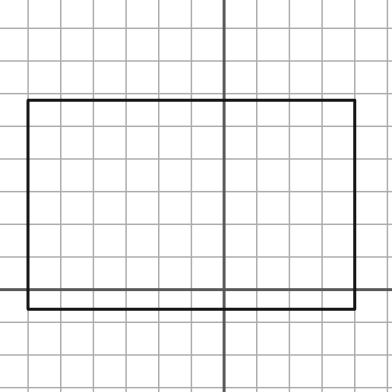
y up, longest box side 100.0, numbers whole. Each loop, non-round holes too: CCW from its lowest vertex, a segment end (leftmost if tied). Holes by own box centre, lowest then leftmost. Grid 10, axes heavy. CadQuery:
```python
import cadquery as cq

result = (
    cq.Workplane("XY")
    .moveTo(-60.0, -6.0)
    .lineTo(40.0, -6.0)
    .lineTo(40.0, 58.0)
    .lineTo(-60.0, 58.0)
    .close()
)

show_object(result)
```